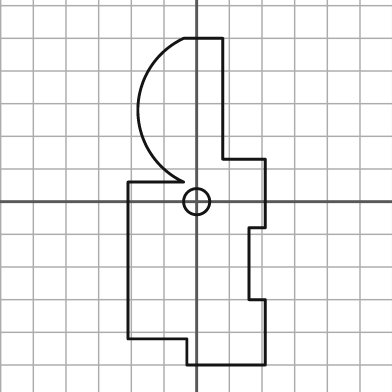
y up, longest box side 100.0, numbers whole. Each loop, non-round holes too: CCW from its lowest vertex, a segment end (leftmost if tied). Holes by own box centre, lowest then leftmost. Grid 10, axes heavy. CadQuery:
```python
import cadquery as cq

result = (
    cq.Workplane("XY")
    .moveTo(-3.0, -50.0)
    .lineTo(21.0, -50.0)
    .lineTo(21.0, -30.0)
    .lineTo(16.0, -30.0)
    .lineTo(16.0, -8.0)
    .lineTo(21.0, -8.0)
    .lineTo(21.0, 13.0)
    .lineTo(8.0, 13.0)
    .lineTo(8.0, 50.0)
    .lineTo(-4.0, 50.0)
    .threePointArc((-18.0, 28.0), (-4.0, 6.0))
    .lineTo(-21.0, 6.0)
    .lineTo(-21.0, -42.0)
    .lineTo(-3.0, -42.0)
    .close()
    .moveTo(0.0, 0.0)
    .circle(4.0)
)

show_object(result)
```